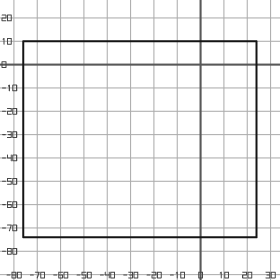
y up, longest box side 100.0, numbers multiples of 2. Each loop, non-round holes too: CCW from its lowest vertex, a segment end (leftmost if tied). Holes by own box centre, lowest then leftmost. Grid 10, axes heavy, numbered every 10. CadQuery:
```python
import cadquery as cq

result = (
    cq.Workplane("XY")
    .moveTo(-76.0, -74.0)
    .lineTo(24.0, -74.0)
    .lineTo(24.0, 10.0)
    .lineTo(-76.0, 10.0)
    .close()
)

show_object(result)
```